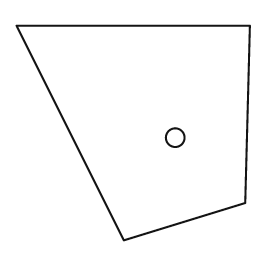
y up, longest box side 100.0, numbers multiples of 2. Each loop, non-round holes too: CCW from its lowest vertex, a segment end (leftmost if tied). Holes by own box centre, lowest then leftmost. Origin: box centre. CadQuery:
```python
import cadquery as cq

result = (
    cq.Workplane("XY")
    .moveTo(-4.0, -46.0)
    .lineTo(48.0, -30.0)
    .lineTo(50.0, 46.0)
    .lineTo(-50.0, 46.0)
    .close()
    .moveTo(18.0, -2.0)
    .circle(4.0)
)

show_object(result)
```